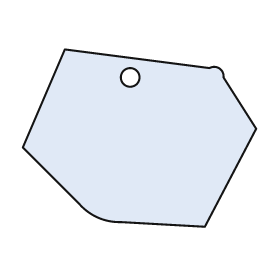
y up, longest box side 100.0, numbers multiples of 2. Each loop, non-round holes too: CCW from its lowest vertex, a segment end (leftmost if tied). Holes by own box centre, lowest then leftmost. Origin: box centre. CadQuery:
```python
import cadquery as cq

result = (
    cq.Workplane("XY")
    .moveTo(28.0, -38.0)
    .lineTo(50.0, 4.0)
    .lineTo(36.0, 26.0)
    .threePointArc((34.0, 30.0), (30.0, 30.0))
    .lineTo(-32.0, 38.0)
    .lineTo(-50.0, -4.0)
    .lineTo(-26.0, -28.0)
    .threePointArc((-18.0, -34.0), (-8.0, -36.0))
    .close()
    .moveTo(-4.0, 26.0)
    .circle(4.0)
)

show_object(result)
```